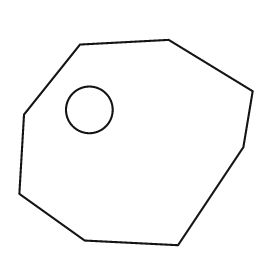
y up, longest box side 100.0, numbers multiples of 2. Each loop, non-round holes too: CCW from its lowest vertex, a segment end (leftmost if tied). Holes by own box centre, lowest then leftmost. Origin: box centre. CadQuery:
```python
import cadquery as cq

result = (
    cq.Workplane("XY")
    .moveTo(18.0, -44.0)
    .lineTo(46.0, -2.0)
    .lineTo(50.0, 22.0)
    .lineTo(14.0, 44.0)
    .lineTo(-24.0, 42.0)
    .lineTo(-48.0, 12.0)
    .lineTo(-50.0, -22.0)
    .lineTo(-22.0, -42.0)
    .close()
    .moveTo(-20.0, 14.0)
    .circle(10.0)
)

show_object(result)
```